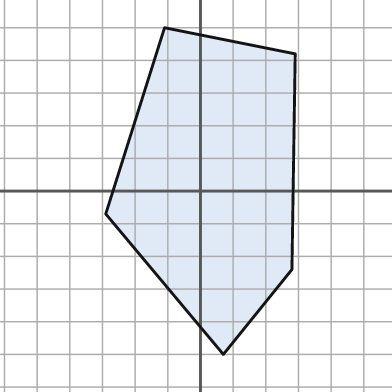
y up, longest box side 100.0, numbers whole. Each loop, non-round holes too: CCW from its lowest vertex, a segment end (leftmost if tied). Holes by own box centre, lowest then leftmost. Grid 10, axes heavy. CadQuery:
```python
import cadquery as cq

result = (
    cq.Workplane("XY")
    .moveTo(7.0, -50.0)
    .lineTo(28.0, -24.0)
    .lineTo(29.0, 42.0)
    .lineTo(-11.0, 50.0)
    .lineTo(-29.0, -7.0)
    .close()
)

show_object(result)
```